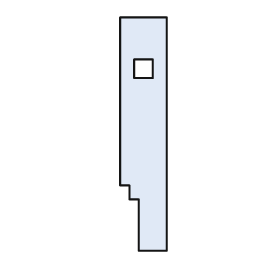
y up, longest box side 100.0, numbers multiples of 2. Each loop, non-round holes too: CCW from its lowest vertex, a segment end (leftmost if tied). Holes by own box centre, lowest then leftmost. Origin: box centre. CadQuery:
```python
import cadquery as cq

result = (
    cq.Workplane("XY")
    .moveTo(-2.0, -50.0)
    .lineTo(10.0, -50.0)
    .lineTo(10.0, 50.0)
    .lineTo(-10.0, 50.0)
    .lineTo(-10.0, -22.0)
    .lineTo(-6.0, -22.0)
    .lineTo(-6.0, -28.0)
    .lineTo(-2.0, -28.0)
    .close()
    .moveTo(-4.0, 24.0)
    .lineTo(4.0, 24.0)
    .lineTo(4.0, 32.0)
    .lineTo(-4.0, 32.0)
    .close()
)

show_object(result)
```